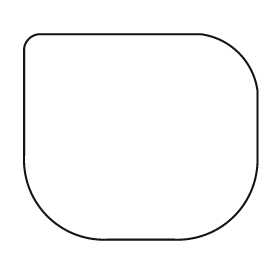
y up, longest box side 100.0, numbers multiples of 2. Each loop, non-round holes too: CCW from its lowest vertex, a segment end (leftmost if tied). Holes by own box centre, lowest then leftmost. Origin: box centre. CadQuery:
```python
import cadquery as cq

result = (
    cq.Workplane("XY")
    .moveTo(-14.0, -44.0)
    .lineTo(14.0, -44.0)
    .threePointArc((40.0, -34.0), (50.0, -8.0))
    .lineTo(50.0, 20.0)
    .threePointArc((42.0, 36.0), (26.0, 44.0))
    .lineTo(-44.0, 44.0)
    .threePointArc((-48.0, 42.0), (-50.0, 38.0))
    .lineTo(-50.0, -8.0)
    .threePointArc((-40.0, -34.0), (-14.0, -44.0))
    .close()
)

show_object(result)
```